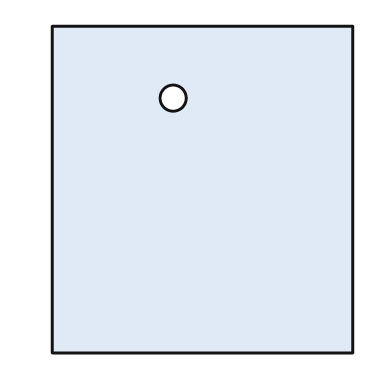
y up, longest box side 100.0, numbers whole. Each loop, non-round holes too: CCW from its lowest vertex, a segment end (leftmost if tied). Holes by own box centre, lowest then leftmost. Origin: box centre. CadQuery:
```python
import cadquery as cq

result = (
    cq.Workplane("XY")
    .moveTo(-46.0, -50.0)
    .lineTo(46.0, -50.0)
    .lineTo(46.0, 50.0)
    .lineTo(-46.0, 50.0)
    .close()
    .moveTo(-9.0, 28.0)
    .circle(4.0)
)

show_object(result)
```